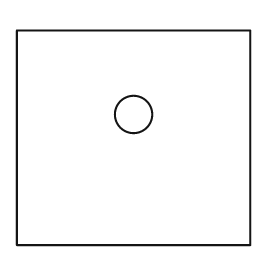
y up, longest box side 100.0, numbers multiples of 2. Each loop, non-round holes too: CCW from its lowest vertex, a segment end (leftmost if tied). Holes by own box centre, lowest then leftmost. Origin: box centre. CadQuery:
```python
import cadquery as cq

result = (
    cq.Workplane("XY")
    .moveTo(-50.0, -46.0)
    .lineTo(50.0, -46.0)
    .lineTo(50.0, 46.0)
    .lineTo(-50.0, 46.0)
    .close()
    .moveTo(0.0, 10.0)
    .circle(8.0)
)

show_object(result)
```